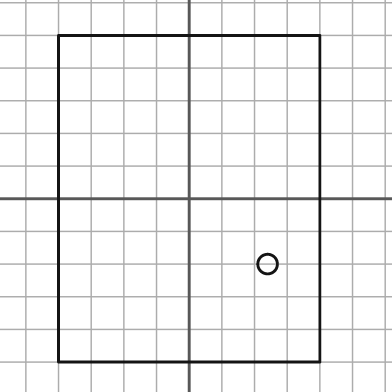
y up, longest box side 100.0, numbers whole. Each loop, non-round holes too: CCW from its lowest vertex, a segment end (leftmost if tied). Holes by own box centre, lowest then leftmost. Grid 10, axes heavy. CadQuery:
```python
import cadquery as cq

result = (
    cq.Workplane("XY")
    .moveTo(-40.0, -50.0)
    .lineTo(40.0, -50.0)
    .lineTo(40.0, 50.0)
    .lineTo(-40.0, 50.0)
    .close()
    .moveTo(24.0, -20.0)
    .circle(3.0)
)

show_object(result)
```